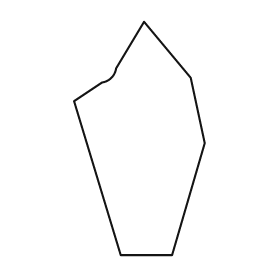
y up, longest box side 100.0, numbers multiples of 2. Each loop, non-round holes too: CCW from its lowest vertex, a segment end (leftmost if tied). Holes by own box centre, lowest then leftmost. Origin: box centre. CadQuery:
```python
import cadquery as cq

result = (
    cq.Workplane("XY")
    .moveTo(-8.0, -50.0)
    .lineTo(14.0, -50.0)
    .lineTo(28.0, -2.0)
    .lineTo(22.0, 26.0)
    .lineTo(2.0, 50.0)
    .lineTo(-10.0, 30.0)
    .threePointArc((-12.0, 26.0), (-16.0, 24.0))
    .lineTo(-28.0, 16.0)
    .close()
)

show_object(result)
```